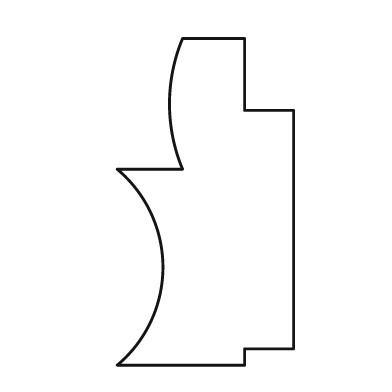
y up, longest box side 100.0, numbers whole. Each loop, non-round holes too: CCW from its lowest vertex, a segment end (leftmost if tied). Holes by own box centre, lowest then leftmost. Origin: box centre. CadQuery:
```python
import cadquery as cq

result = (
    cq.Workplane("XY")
    .moveTo(-27.0, -50.0)
    .lineTo(12.0, -50.0)
    .lineTo(12.0, -45.0)
    .lineTo(27.0, -45.0)
    .lineTo(27.0, 28.0)
    .lineTo(12.0, 28.0)
    .lineTo(12.0, 50.0)
    .lineTo(-7.0, 50.0)
    .threePointArc((-11.0, 30.0), (-7.0, 10.0))
    .lineTo(-27.0, 10.0)
    .threePointArc((-13.0, -20.0), (-27.0, -50.0))
    .close()
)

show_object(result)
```